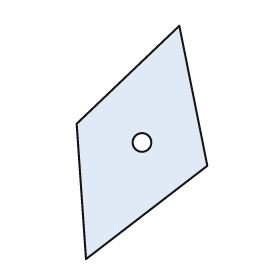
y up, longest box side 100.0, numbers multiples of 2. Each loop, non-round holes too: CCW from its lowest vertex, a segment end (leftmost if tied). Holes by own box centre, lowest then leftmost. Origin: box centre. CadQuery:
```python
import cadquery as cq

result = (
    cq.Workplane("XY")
    .moveTo(-24.0, -50.0)
    .lineTo(28.0, -10.0)
    .lineTo(16.0, 50.0)
    .lineTo(-28.0, 8.0)
    .close()
    .moveTo(0.0, 0.0)
    .circle(4.0)
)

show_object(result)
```